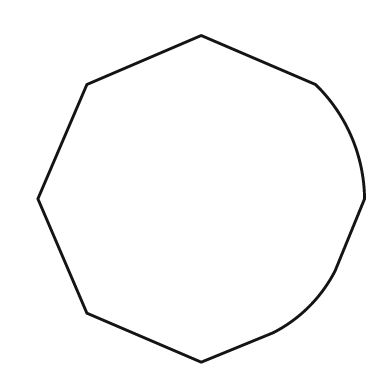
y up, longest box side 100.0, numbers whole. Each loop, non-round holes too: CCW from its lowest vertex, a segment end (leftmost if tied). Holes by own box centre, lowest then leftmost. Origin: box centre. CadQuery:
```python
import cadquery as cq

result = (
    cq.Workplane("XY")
    .moveTo(0.0, -50.0)
    .lineTo(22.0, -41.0)
    .threePointArc((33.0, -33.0), (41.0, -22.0))
    .lineTo(50.0, 0.0)
    .threePointArc((46.0, 19.0), (35.0, 35.0))
    .lineTo(0.0, 50.0)
    .lineTo(-35.0, 35.0)
    .lineTo(-50.0, 0.0)
    .lineTo(-35.0, -35.0)
    .close()
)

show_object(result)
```